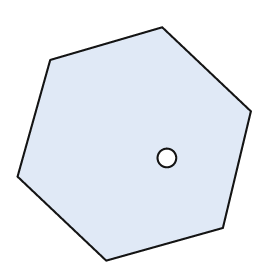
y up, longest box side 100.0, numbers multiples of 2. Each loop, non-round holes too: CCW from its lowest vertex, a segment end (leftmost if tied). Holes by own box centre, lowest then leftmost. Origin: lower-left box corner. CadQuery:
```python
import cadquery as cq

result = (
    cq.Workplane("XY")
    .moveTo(38.0, 0.0)
    .lineTo(88.0, 14.0)
    .lineTo(100.0, 64.0)
    .lineTo(62.0, 100.0)
    .lineTo(14.0, 86.0)
    .lineTo(0.0, 36.0)
    .close()
    .moveTo(64.0, 44.0)
    .circle(4.0)
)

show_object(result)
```